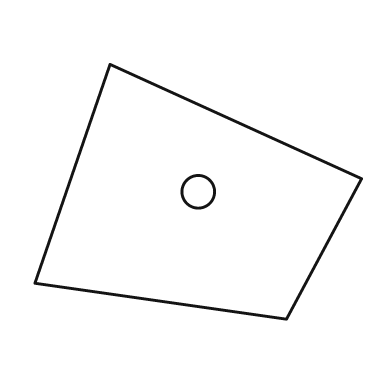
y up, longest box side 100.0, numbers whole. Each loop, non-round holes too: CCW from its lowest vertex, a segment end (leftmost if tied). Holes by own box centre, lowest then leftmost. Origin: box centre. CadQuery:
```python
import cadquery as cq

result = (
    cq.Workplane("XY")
    .moveTo(27.0, -39.0)
    .lineTo(50.0, 4.0)
    .lineTo(-27.0, 39.0)
    .lineTo(-50.0, -28.0)
    .close()
    .moveTo(0.0, 0.0)
    .circle(5.0)
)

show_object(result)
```